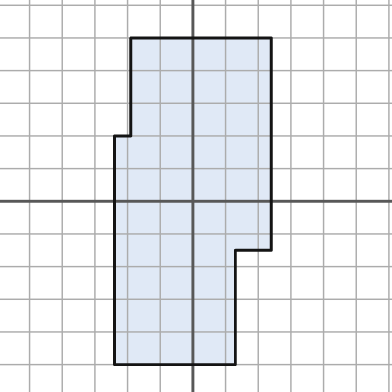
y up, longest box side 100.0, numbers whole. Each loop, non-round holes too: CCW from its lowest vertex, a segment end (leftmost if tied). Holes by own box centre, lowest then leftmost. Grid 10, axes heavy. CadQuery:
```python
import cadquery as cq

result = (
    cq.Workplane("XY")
    .moveTo(-24.0, -50.0)
    .lineTo(13.0, -50.0)
    .lineTo(13.0, -15.0)
    .lineTo(24.0, -15.0)
    .lineTo(24.0, 50.0)
    .lineTo(-19.0, 50.0)
    .lineTo(-19.0, 20.0)
    .lineTo(-24.0, 20.0)
    .close()
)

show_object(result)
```